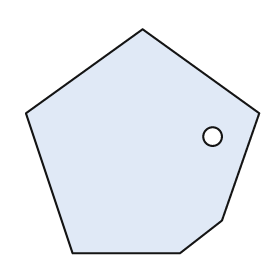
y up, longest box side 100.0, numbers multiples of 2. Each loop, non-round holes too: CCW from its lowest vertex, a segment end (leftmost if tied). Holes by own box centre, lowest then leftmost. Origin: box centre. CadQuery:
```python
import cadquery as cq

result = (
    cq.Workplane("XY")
    .moveTo(-30.0, -48.0)
    .lineTo(16.0, -48.0)
    .lineTo(34.0, -34.0)
    .lineTo(50.0, 12.0)
    .lineTo(0.0, 48.0)
    .lineTo(-50.0, 12.0)
    .close()
    .moveTo(30.0, 2.0)
    .circle(4.0)
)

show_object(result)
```